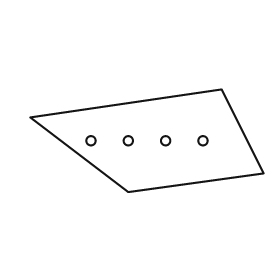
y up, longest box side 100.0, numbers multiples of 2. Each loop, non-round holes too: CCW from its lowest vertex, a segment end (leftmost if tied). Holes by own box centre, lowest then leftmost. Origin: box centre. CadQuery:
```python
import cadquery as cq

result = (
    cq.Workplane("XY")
    .moveTo(-8.0, -22.0)
    .lineTo(50.0, -14.0)
    .lineTo(32.0, 22.0)
    .lineTo(-50.0, 10.0)
    .close()
    .moveTo(-24.0, 0.0)
    .circle(2.0)
    .moveTo(-8.0, 0.0)
    .circle(2.0)
    .moveTo(8.0, 0.0)
    .circle(2.0)
    .moveTo(24.0, 0.0)
    .circle(2.0)
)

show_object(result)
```